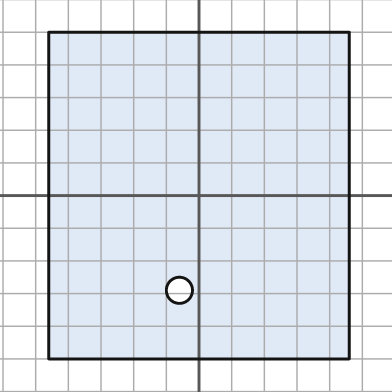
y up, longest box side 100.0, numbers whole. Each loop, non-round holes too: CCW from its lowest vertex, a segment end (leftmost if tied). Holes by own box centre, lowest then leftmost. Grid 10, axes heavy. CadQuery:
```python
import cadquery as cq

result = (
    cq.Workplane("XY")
    .moveTo(-46.0, -50.0)
    .lineTo(46.0, -50.0)
    .lineTo(46.0, 50.0)
    .lineTo(-46.0, 50.0)
    .close()
    .moveTo(-6.0, -29.0)
    .circle(4.0)
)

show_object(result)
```